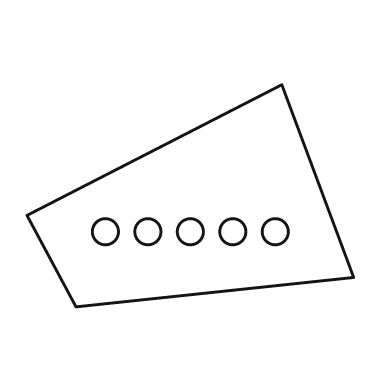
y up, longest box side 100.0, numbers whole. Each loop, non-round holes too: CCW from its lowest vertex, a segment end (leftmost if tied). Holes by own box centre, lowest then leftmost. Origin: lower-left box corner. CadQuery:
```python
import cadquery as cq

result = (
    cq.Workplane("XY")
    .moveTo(15.0, 0.0)
    .lineTo(100.0, 9.0)
    .lineTo(78.0, 68.0)
    .lineTo(0.0, 28.0)
    .close()
    .moveTo(24.0, 23.0)
    .circle(4.0)
    .moveTo(37.0, 23.0)
    .circle(4.0)
    .moveTo(50.0, 23.0)
    .circle(4.0)
    .moveTo(63.0, 23.0)
    .circle(4.0)
    .moveTo(76.0, 23.0)
    .circle(4.0)
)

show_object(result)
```